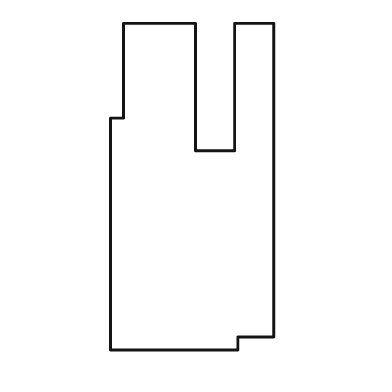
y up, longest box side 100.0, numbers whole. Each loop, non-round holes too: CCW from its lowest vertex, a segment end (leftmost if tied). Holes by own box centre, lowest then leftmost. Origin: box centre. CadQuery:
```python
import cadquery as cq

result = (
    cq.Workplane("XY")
    .moveTo(-25.0, -50.0)
    .lineTo(14.0, -50.0)
    .lineTo(14.0, -46.0)
    .lineTo(25.0, -46.0)
    .lineTo(25.0, 50.0)
    .lineTo(13.0, 50.0)
    .lineTo(13.0, 11.0)
    .lineTo(1.0, 11.0)
    .lineTo(1.0, 50.0)
    .lineTo(-21.0, 50.0)
    .lineTo(-21.0, 21.0)
    .lineTo(-25.0, 21.0)
    .close()
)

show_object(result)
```